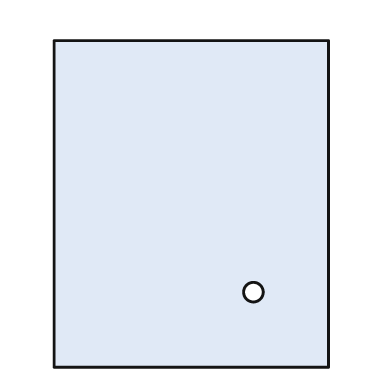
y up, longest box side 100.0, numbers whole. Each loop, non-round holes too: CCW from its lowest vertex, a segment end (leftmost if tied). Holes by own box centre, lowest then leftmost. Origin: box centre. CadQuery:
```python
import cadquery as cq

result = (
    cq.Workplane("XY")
    .moveTo(-42.0, -50.0)
    .lineTo(42.0, -50.0)
    .lineTo(42.0, 50.0)
    .lineTo(-42.0, 50.0)
    .close()
    .moveTo(19.0, -27.0)
    .circle(3.0)
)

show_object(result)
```